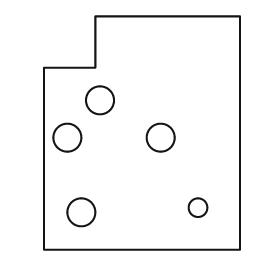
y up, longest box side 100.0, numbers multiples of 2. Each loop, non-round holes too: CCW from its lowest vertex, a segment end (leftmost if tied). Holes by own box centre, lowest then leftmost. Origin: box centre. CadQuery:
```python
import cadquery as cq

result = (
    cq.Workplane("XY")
    .moveTo(-42.0, -50.0)
    .lineTo(42.0, -50.0)
    .lineTo(42.0, 50.0)
    .lineTo(-20.0, 50.0)
    .lineTo(-20.0, 28.0)
    .lineTo(-42.0, 28.0)
    .close()
    .moveTo(-26.0, -34.0)
    .circle(6.0)
    .moveTo(24.0, -32.0)
    .circle(4.0)
    .moveTo(-32.0, -2.0)
    .circle(6.0)
    .moveTo(8.0, -2.0)
    .circle(6.0)
    .moveTo(-18.0, 14.0)
    .circle(6.0)
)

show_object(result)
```